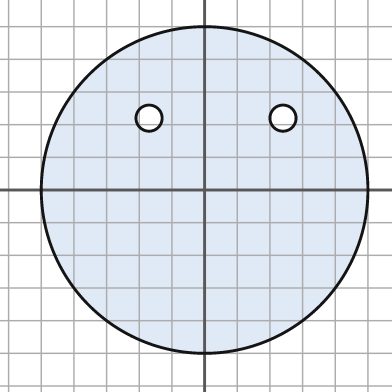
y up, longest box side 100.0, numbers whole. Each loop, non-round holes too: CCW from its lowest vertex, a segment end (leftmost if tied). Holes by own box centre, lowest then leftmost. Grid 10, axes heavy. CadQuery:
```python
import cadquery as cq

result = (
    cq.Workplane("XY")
    .moveTo(0.0, 0.0)
    .circle(50.0)
    .moveTo(-17.0, 22.0)
    .circle(4.0)
    .moveTo(24.0, 22.0)
    .circle(4.0)
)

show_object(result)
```